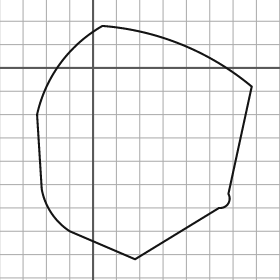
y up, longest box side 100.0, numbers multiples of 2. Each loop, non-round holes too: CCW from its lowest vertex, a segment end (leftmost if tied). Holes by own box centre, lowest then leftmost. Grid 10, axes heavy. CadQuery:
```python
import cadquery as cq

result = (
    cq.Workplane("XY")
    .moveTo(18.0, -82.0)
    .lineTo(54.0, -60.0)
    .threePointArc((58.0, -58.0), (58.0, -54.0))
    .lineTo(68.0, -8.0)
    .threePointArc((38.0, 10.0), (4.0, 18.0))
    .threePointArc((-14.0, 2.0), (-24.0, -20.0))
    .lineTo(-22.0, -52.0)
    .threePointArc((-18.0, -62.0), (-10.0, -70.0))
    .close()
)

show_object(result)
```